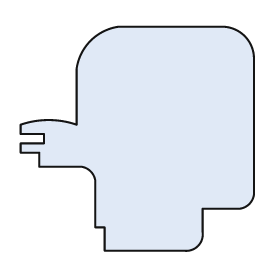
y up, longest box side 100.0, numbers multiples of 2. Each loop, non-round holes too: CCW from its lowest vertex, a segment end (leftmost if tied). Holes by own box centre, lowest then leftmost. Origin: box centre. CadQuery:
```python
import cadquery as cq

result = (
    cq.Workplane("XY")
    .moveTo(-14.0, -48.0)
    .lineTo(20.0, -48.0)
    .threePointArc((26.0, -46.0), (28.0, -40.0))
    .lineTo(28.0, -30.0)
    .lineTo(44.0, -30.0)
    .threePointArc((48.0, -28.0), (50.0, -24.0))
    .lineTo(50.0, 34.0)
    .threePointArc((46.0, 44.0), (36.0, 48.0))
    .lineTo(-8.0, 48.0)
    .threePointArc((-20.0, 42.0), (-26.0, 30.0))
    .lineTo(-26.0, 6.0)
    .threePointArc((-38.0, 8.0), (-50.0, 6.0))
    .lineTo(-50.0, 2.0)
    .lineTo(-40.0, 2.0)
    .lineTo(-40.0, -2.0)
    .lineTo(-50.0, -2.0)
    .lineTo(-50.0, -6.0)
    .lineTo(-42.0, -6.0)
    .lineTo(-42.0, -12.0)
    .lineTo(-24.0, -12.0)
    .threePointArc((-20.0, -14.0), (-18.0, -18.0))
    .lineTo(-18.0, -38.0)
    .lineTo(-14.0, -38.0)
    .close()
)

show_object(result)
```